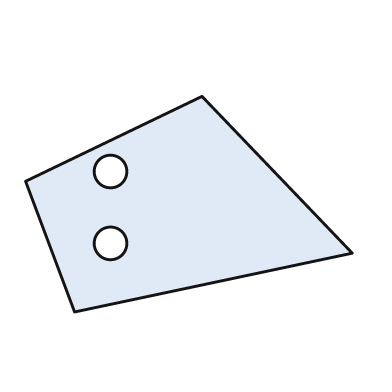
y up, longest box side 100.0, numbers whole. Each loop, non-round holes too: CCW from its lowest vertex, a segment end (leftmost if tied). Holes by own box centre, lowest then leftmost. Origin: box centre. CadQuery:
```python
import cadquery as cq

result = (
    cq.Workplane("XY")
    .moveTo(-35.0, -33.0)
    .lineTo(50.0, -15.0)
    .lineTo(4.0, 33.0)
    .lineTo(-50.0, 7.0)
    .close()
    .moveTo(-24.0, -12.0)
    .circle(5.0)
    .moveTo(-24.0, 10.0)
    .circle(5.0)
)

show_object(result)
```